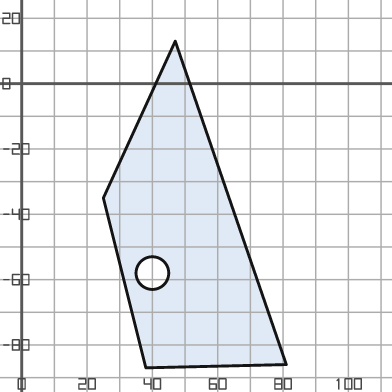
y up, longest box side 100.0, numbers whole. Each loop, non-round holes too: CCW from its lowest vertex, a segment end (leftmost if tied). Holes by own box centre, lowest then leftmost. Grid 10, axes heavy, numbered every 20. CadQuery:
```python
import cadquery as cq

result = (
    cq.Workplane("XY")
    .moveTo(38.0, -87.0)
    .lineTo(81.0, -86.0)
    .lineTo(47.0, 13.0)
    .lineTo(25.0, -35.0)
    .close()
    .moveTo(40.0, -58.0)
    .circle(5.0)
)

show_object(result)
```